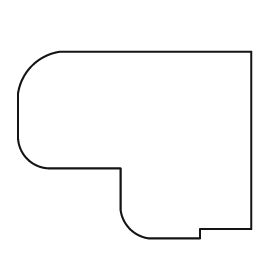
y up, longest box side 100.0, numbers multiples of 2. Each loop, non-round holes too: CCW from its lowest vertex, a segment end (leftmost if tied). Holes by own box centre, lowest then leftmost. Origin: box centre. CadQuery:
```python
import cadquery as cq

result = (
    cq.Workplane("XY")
    .moveTo(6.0, -40.0)
    .lineTo(28.0, -40.0)
    .lineTo(28.0, -36.0)
    .lineTo(50.0, -36.0)
    .lineTo(50.0, 40.0)
    .lineTo(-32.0, 40.0)
    .threePointArc((-44.0, 34.0), (-50.0, 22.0))
    .lineTo(-50.0, 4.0)
    .threePointArc((-46.0, -6.0), (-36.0, -10.0))
    .lineTo(-6.0, -10.0)
    .lineTo(-6.0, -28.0)
    .threePointArc((-2.0, -36.0), (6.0, -40.0))
    .close()
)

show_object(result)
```